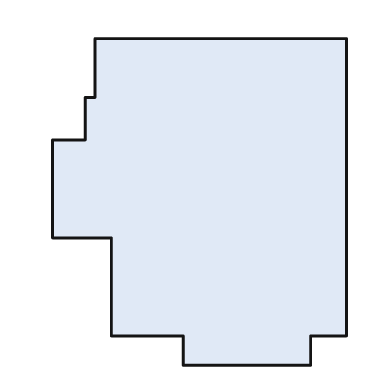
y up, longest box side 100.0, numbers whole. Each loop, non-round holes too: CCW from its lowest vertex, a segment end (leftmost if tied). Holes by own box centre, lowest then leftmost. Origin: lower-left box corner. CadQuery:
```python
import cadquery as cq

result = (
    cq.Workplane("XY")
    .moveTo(40.0, 0.0)
    .lineTo(79.0, 0.0)
    .lineTo(79.0, 9.0)
    .lineTo(90.0, 9.0)
    .lineTo(90.0, 100.0)
    .lineTo(13.0, 100.0)
    .lineTo(13.0, 82.0)
    .lineTo(10.0, 82.0)
    .lineTo(10.0, 69.0)
    .lineTo(0.0, 69.0)
    .lineTo(0.0, 39.0)
    .lineTo(18.0, 39.0)
    .lineTo(18.0, 9.0)
    .lineTo(40.0, 9.0)
    .close()
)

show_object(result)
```